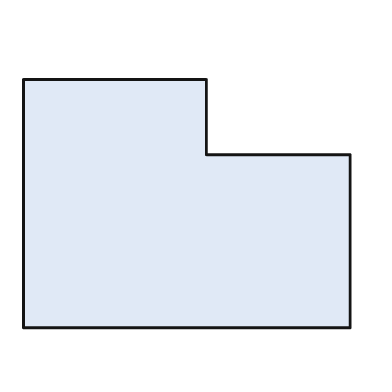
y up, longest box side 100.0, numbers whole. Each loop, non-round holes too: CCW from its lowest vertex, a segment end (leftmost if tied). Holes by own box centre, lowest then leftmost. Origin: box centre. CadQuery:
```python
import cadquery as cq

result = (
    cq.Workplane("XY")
    .moveTo(-50.0, -38.0)
    .lineTo(50.0, -38.0)
    .lineTo(50.0, 15.0)
    .lineTo(6.0, 15.0)
    .lineTo(6.0, 38.0)
    .lineTo(-50.0, 38.0)
    .close()
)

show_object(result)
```